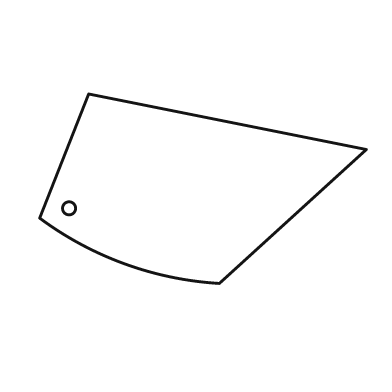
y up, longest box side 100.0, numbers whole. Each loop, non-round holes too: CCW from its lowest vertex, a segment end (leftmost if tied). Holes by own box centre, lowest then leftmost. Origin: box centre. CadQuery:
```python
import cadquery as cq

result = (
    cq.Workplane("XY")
    .moveTo(5.0, -29.0)
    .lineTo(50.0, 12.0)
    .lineTo(-35.0, 29.0)
    .lineTo(-50.0, -9.0)
    .threePointArc((-24.0, -23.0), (5.0, -29.0))
    .close()
    .moveTo(-41.0, -6.0)
    .circle(2.0)
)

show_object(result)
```